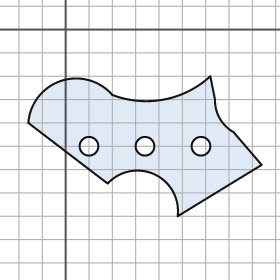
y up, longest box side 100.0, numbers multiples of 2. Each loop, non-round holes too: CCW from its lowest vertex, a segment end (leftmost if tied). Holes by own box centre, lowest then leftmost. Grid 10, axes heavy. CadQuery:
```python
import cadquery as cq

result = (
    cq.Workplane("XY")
    .moveTo(48.0, -80.0)
    .lineTo(84.0, -58.0)
    .lineTo(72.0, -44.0)
    .threePointArc((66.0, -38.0), (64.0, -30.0))
    .lineTo(62.0, -20.0)
    .threePointArc((42.0, -30.0), (20.0, -28.0))
    .threePointArc((-2.0, -22.0), (-16.0, -40.0))
    .lineTo(18.0, -66.0)
    .threePointArc((38.0, -62.0), (48.0, -80.0))
    .close()
    .moveTo(10.0, -50.0)
    .circle(4.0)
    .moveTo(34.0, -50.0)
    .circle(4.0)
    .moveTo(58.0, -50.0)
    .circle(4.0)
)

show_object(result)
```